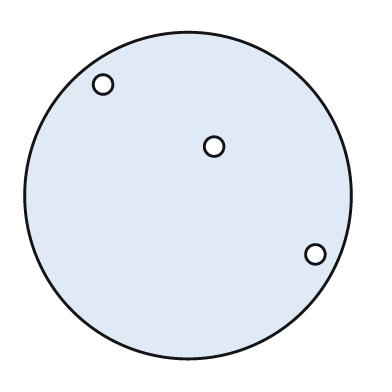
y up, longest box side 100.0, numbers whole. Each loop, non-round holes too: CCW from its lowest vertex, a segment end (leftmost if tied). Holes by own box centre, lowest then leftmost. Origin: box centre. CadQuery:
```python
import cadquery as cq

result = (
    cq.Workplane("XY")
    .moveTo(0.0, 0.0)
    .circle(50.0)
    .moveTo(39.0, -18.0)
    .circle(3.0)
    .moveTo(8.0, 15.0)
    .circle(3.0)
    .moveTo(-26.0, 34.0)
    .circle(3.0)
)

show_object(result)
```